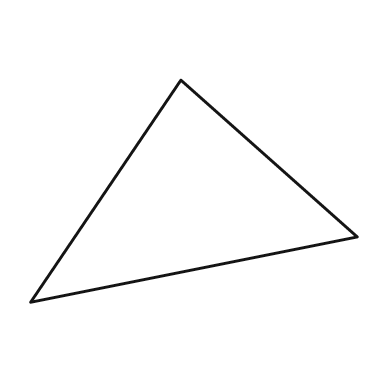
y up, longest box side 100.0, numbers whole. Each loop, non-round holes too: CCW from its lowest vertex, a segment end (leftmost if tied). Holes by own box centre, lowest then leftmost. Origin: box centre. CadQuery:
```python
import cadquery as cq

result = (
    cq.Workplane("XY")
    .moveTo(-50.0, -34.0)
    .lineTo(50.0, -14.0)
    .lineTo(-4.0, 34.0)
    .close()
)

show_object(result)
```